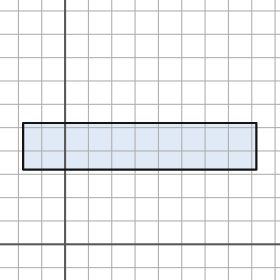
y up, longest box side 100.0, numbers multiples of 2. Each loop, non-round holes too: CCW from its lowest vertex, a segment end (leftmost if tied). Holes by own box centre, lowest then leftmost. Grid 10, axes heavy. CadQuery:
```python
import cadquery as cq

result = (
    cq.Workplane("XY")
    .moveTo(-18.0, 32.0)
    .lineTo(82.0, 32.0)
    .lineTo(82.0, 52.0)
    .lineTo(-18.0, 52.0)
    .close()
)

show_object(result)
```